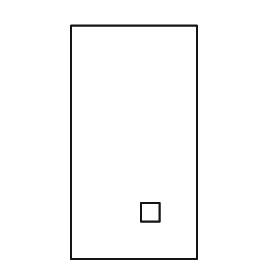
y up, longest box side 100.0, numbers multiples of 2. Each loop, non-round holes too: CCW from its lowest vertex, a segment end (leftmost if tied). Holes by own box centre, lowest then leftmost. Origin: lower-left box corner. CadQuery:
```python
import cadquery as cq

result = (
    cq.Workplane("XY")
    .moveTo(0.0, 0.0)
    .lineTo(54.0, 0.0)
    .lineTo(54.0, 100.0)
    .lineTo(0.0, 100.0)
    .close()
    .moveTo(30.0, 16.0)
    .lineTo(38.0, 16.0)
    .lineTo(38.0, 24.0)
    .lineTo(30.0, 24.0)
    .close()
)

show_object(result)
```